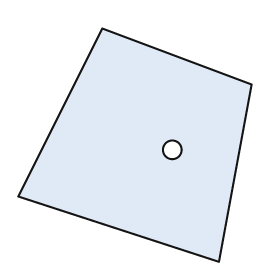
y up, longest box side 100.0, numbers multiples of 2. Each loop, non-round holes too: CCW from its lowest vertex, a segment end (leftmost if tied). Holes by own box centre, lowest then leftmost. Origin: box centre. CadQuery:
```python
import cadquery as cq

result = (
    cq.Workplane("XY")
    .moveTo(36.0, -50.0)
    .lineTo(50.0, 26.0)
    .lineTo(-14.0, 50.0)
    .lineTo(-50.0, -22.0)
    .close()
    .moveTo(16.0, -2.0)
    .circle(4.0)
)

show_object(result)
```